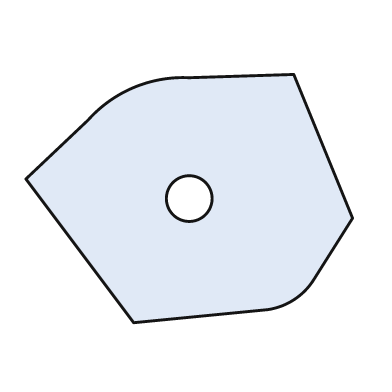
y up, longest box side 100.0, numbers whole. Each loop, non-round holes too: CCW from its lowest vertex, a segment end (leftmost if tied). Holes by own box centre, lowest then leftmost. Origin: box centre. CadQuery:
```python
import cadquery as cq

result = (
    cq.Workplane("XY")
    .moveTo(-17.0, -38.0)
    .lineTo(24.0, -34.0)
    .threePointArc((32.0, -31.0), (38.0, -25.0))
    .lineTo(50.0, -6.0)
    .lineTo(32.0, 38.0)
    .lineTo(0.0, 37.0)
    .threePointArc((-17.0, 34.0), (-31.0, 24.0))
    .lineTo(-50.0, 6.0)
    .close()
    .moveTo(0.0, 0.0)
    .circle(7.0)
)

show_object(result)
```